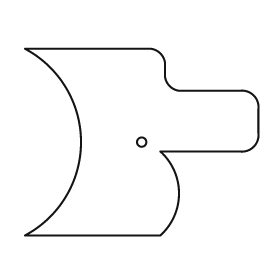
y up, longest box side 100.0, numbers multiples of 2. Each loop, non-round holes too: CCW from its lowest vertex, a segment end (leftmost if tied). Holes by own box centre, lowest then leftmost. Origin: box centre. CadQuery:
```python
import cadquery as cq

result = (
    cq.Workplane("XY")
    .moveTo(-50.0, -40.0)
    .lineTo(8.0, -40.0)
    .threePointArc((16.0, -22.0), (8.0, -4.0))
    .lineTo(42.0, -4.0)
    .threePointArc((48.0, -2.0), (50.0, 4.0))
    .lineTo(50.0, 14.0)
    .threePointArc((48.0, 20.0), (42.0, 22.0))
    .lineTo(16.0, 22.0)
    .threePointArc((12.0, 24.0), (10.0, 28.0))
    .lineTo(10.0, 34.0)
    .threePointArc((8.0, 38.0), (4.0, 40.0))
    .lineTo(-50.0, 40.0)
    .threePointArc((-26.0, 0.0), (-50.0, -40.0))
    .close()
    .moveTo(0.0, 0.0)
    .circle(2.0)
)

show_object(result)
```